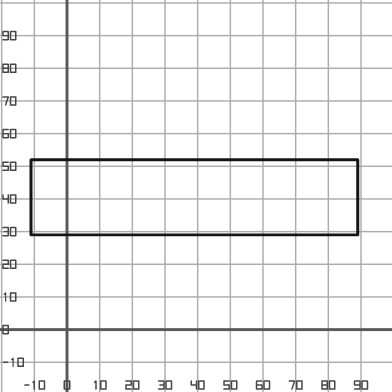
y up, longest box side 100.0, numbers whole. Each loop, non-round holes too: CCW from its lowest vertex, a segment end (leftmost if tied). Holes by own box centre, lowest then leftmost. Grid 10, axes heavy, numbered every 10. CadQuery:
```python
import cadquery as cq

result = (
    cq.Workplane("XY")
    .moveTo(-11.0, 29.0)
    .lineTo(89.0, 29.0)
    .lineTo(89.0, 52.0)
    .lineTo(-11.0, 52.0)
    .close()
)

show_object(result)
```